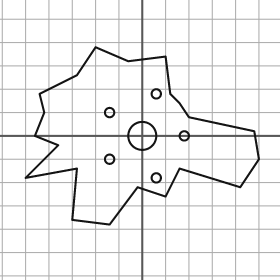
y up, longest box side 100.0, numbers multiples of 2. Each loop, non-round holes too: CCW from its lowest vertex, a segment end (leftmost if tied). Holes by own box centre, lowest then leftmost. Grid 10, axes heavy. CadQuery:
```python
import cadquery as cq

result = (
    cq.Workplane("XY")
    .moveTo(-14.0, -38.0)
    .lineTo(-2.0, -22.0)
    .lineTo(10.0, -26.0)
    .lineTo(16.0, -14.0)
    .lineTo(42.0, -22.0)
    .lineTo(50.0, -10.0)
    .lineTo(48.0, 2.0)
    .lineTo(20.0, 8.0)
    .lineTo(16.0, 14.0)
    .lineTo(12.0, 18.0)
    .lineTo(10.0, 34.0)
    .lineTo(-6.0, 32.0)
    .lineTo(-20.0, 38.0)
    .lineTo(-28.0, 26.0)
    .lineTo(-44.0, 18.0)
    .lineTo(-42.0, 10.0)
    .lineTo(-46.0, 0.0)
    .lineTo(-36.0, -4.0)
    .lineTo(-50.0, -18.0)
    .lineTo(-28.0, -14.0)
    .lineTo(-30.0, -36.0)
    .close()
    .moveTo(6.0, -18.0)
    .circle(2.0)
    .moveTo(-14.0, -10.0)
    .circle(2.0)
    .moveTo(0.0, 0.0)
    .circle(6.0)
    .moveTo(18.0, 0.0)
    .circle(2.0)
    .moveTo(-14.0, 10.0)
    .circle(2.0)
    .moveTo(6.0, 18.0)
    .circle(2.0)
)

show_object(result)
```